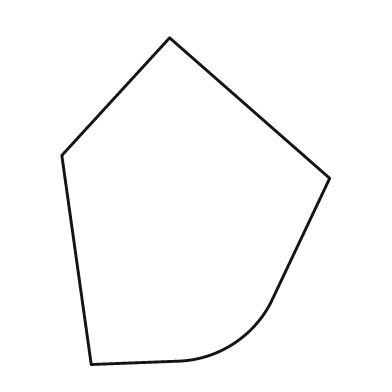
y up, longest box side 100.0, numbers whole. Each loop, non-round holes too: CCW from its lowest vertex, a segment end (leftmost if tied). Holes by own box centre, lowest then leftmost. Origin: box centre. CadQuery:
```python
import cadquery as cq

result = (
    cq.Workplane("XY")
    .moveTo(-32.0, -50.0)
    .lineTo(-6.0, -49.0)
    .threePointArc((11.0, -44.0), (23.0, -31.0))
    .lineTo(41.0, 7.0)
    .lineTo(-8.0, 50.0)
    .lineTo(-41.0, 14.0)
    .close()
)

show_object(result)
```